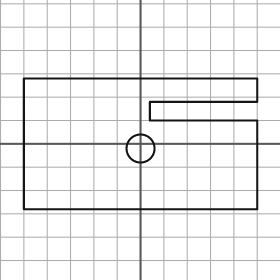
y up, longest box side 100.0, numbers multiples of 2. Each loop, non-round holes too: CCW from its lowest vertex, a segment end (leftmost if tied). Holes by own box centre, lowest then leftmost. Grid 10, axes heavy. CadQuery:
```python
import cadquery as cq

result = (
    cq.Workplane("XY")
    .moveTo(-50.0, -28.0)
    .lineTo(50.0, -28.0)
    .lineTo(50.0, 10.0)
    .lineTo(4.0, 10.0)
    .lineTo(4.0, 18.0)
    .lineTo(50.0, 18.0)
    .lineTo(50.0, 28.0)
    .lineTo(-50.0, 28.0)
    .close()
    .moveTo(0.0, -2.0)
    .circle(6.0)
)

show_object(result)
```